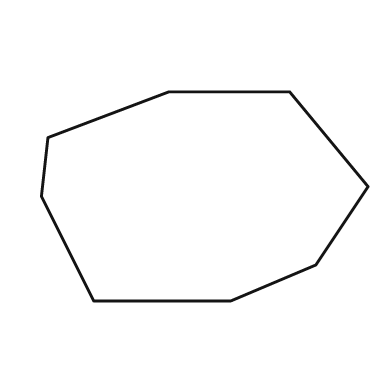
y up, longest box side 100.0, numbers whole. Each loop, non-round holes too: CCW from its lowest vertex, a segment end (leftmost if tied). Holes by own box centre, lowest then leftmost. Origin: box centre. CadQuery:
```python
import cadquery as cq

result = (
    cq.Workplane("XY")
    .moveTo(-34.0, -32.0)
    .lineTo(8.0, -32.0)
    .lineTo(34.0, -21.0)
    .lineTo(50.0, 3.0)
    .lineTo(26.0, 32.0)
    .lineTo(-11.0, 32.0)
    .lineTo(-48.0, 18.0)
    .lineTo(-50.0, 0.0)
    .close()
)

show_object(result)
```